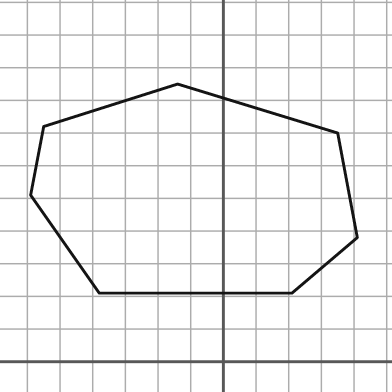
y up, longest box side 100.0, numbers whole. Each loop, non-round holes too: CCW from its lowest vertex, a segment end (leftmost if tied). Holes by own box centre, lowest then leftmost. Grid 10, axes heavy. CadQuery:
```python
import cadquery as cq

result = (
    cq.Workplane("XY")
    .moveTo(-38.0, 21.0)
    .lineTo(21.0, 21.0)
    .lineTo(41.0, 38.0)
    .lineTo(35.0, 70.0)
    .lineTo(-14.0, 85.0)
    .lineTo(-55.0, 72.0)
    .lineTo(-59.0, 51.0)
    .close()
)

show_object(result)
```